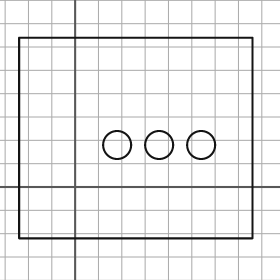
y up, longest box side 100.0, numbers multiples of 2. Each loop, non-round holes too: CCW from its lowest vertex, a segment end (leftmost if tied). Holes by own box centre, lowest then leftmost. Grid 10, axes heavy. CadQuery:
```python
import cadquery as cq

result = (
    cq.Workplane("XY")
    .moveTo(-24.0, -22.0)
    .lineTo(76.0, -22.0)
    .lineTo(76.0, 64.0)
    .lineTo(-24.0, 64.0)
    .close()
    .moveTo(18.0, 18.0)
    .circle(6.0)
    .moveTo(36.0, 18.0)
    .circle(6.0)
    .moveTo(54.0, 18.0)
    .circle(6.0)
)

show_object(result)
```